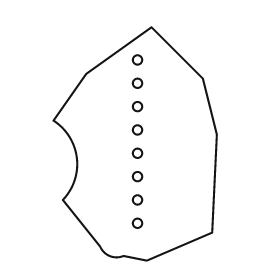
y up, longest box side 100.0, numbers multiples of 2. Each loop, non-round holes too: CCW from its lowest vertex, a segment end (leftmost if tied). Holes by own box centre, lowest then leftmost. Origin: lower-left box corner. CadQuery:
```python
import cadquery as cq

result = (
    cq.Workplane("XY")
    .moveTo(40.0, 0.0)
    .lineTo(68.0, 12.0)
    .lineTo(70.0, 54.0)
    .lineTo(64.0, 78.0)
    .lineTo(42.0, 100.0)
    .lineTo(14.0, 80.0)
    .lineTo(0.0, 60.0)
    .threePointArc((10.0, 44.0), (4.0, 26.0))
    .lineTo(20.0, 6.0)
    .threePointArc((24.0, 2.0), (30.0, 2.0))
    .close()
    .moveTo(36.0, 16.0)
    .circle(2.0)
    .moveTo(36.0, 26.0)
    .circle(2.0)
    .moveTo(36.0, 36.0)
    .circle(2.0)
    .moveTo(36.0, 46.0)
    .circle(2.0)
    .moveTo(36.0, 56.0)
    .circle(2.0)
    .moveTo(36.0, 66.0)
    .circle(2.0)
    .moveTo(36.0, 76.0)
    .circle(2.0)
    .moveTo(36.0, 86.0)
    .circle(2.0)
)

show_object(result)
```